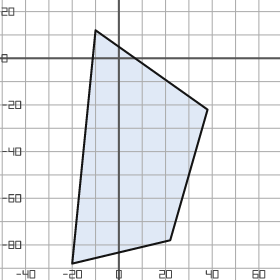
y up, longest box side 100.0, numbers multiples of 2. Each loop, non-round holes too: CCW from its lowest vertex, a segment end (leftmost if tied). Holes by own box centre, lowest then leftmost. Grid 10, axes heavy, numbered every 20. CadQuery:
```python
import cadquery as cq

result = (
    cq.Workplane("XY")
    .moveTo(-20.0, -88.0)
    .lineTo(22.0, -78.0)
    .lineTo(38.0, -22.0)
    .lineTo(-10.0, 12.0)
    .close()
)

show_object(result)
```